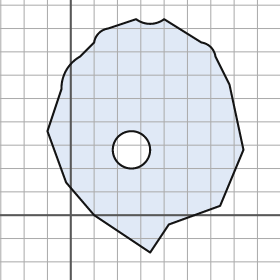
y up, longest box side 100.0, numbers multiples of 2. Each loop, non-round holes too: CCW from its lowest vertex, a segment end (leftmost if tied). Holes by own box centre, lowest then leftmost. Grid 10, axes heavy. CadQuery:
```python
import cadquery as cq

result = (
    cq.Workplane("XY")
    .moveTo(34.0, -16.0)
    .lineTo(42.0, -4.0)
    .lineTo(64.0, 4.0)
    .lineTo(74.0, 28.0)
    .lineTo(68.0, 56.0)
    .lineTo(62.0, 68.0)
    .threePointArc((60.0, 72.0), (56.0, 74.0))
    .lineTo(40.0, 84.0)
    .threePointArc((34.0, 82.0), (28.0, 84.0))
    .lineTo(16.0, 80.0)
    .threePointArc((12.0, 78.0), (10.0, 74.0))
    .lineTo(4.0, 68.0)
    .threePointArc((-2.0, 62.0), (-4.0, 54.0))
    .lineTo(-10.0, 36.0)
    .lineTo(-2.0, 14.0)
    .lineTo(10.0, 0.0)
    .close()
    .moveTo(26.0, 28.0)
    .circle(8.0)
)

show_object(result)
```